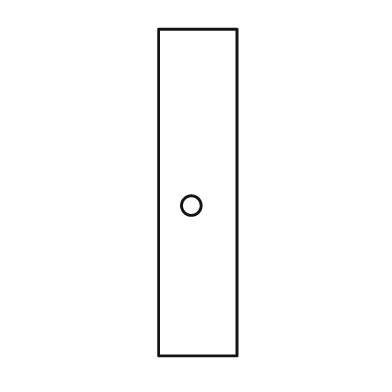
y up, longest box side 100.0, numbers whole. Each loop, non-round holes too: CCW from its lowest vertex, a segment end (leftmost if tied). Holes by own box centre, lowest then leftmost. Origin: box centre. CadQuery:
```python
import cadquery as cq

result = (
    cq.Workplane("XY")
    .moveTo(-12.0, -50.0)
    .lineTo(12.0, -50.0)
    .lineTo(12.0, 50.0)
    .lineTo(-12.0, 50.0)
    .close()
    .moveTo(-2.0, -4.0)
    .circle(3.0)
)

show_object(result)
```